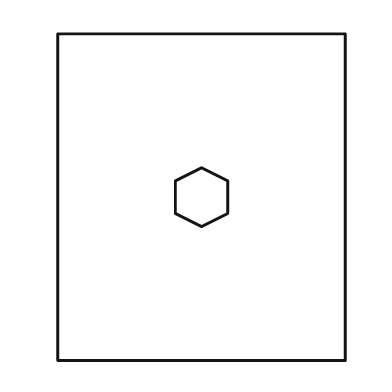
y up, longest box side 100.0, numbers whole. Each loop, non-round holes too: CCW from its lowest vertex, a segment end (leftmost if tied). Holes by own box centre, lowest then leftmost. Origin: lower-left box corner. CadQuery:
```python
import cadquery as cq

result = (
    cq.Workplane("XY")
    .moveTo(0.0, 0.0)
    .lineTo(88.0, 0.0)
    .lineTo(88.0, 100.0)
    .lineTo(0.0, 100.0)
    .close()
    .moveTo(44.0, 41.0)
    .lineTo(52.0, 45.0)
    .lineTo(52.0, 55.0)
    .lineTo(44.0, 59.0)
    .lineTo(36.0, 55.0)
    .lineTo(36.0, 45.0)
    .close()
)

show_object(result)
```